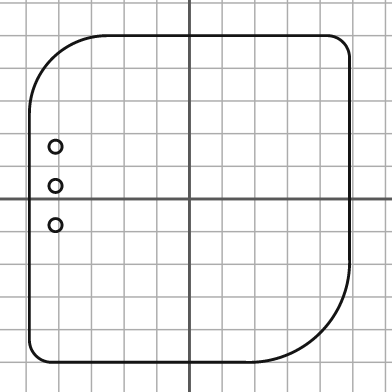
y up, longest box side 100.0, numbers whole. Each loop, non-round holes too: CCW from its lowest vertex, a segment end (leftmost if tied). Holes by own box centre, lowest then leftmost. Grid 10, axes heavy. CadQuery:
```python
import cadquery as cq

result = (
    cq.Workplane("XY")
    .moveTo(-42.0, -50.0)
    .lineTo(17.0, -50.0)
    .threePointArc((40.0, -41.0), (49.0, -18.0))
    .lineTo(49.0, 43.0)
    .threePointArc((47.0, 48.0), (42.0, 50.0))
    .lineTo(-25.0, 50.0)
    .threePointArc((-42.0, 43.0), (-49.0, 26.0))
    .lineTo(-49.0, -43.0)
    .threePointArc((-47.0, -48.0), (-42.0, -50.0))
    .close()
    .moveTo(-41.0, -8.0)
    .circle(2.0)
    .moveTo(-41.0, 4.0)
    .circle(2.0)
    .moveTo(-41.0, 16.0)
    .circle(2.0)
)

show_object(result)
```